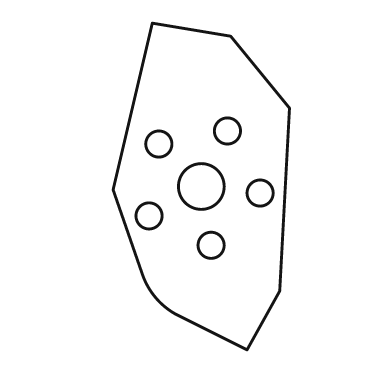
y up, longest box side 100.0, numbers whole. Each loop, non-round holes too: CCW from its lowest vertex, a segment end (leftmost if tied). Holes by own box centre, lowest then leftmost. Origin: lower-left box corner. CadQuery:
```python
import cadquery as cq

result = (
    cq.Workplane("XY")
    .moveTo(41.0, 0.0)
    .lineTo(51.0, 18.0)
    .lineTo(54.0, 74.0)
    .lineTo(36.0, 96.0)
    .lineTo(12.0, 100.0)
    .lineTo(0.0, 49.0)
    .lineTo(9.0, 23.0)
    .threePointArc((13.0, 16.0), (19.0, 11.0))
    .close()
    .moveTo(30.0, 32.0)
    .circle(4.0)
    .moveTo(11.0, 41.0)
    .circle(4.0)
    .moveTo(45.0, 48.0)
    .circle(4.0)
    .moveTo(27.0, 50.0)
    .circle(7.0)
    .moveTo(14.0, 63.0)
    .circle(4.0)
    .moveTo(35.0, 67.0)
    .circle(4.0)
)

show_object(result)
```